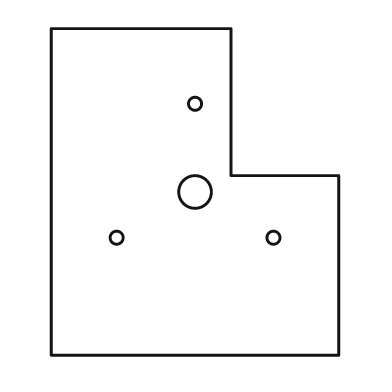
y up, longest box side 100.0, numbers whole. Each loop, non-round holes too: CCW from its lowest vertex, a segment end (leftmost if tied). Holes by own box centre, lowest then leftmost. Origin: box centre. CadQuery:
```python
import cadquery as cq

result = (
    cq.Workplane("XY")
    .moveTo(-44.0, -50.0)
    .lineTo(44.0, -50.0)
    .lineTo(44.0, 5.0)
    .lineTo(11.0, 5.0)
    .lineTo(11.0, 50.0)
    .lineTo(-44.0, 50.0)
    .close()
    .moveTo(-24.0, -14.0)
    .circle(2.0)
    .moveTo(24.0, -14.0)
    .circle(2.0)
    .moveTo(0.0, 0.0)
    .circle(5.0)
    .moveTo(0.0, 27.0)
    .circle(2.0)
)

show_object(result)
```